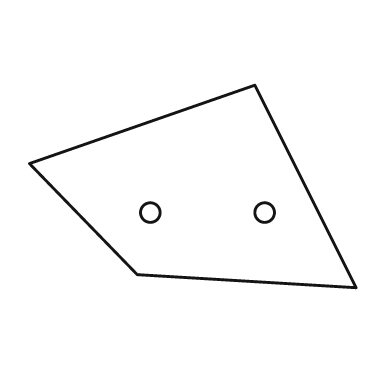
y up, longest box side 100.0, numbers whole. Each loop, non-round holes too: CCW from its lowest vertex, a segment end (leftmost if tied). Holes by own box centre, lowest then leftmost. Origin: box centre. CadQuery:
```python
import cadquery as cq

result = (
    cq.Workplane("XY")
    .moveTo(50.0, -31.0)
    .lineTo(19.0, 31.0)
    .lineTo(-50.0, 7.0)
    .lineTo(-17.0, -27.0)
    .close()
    .moveTo(-13.0, -8.0)
    .circle(3.0)
    .moveTo(22.0, -8.0)
    .circle(3.0)
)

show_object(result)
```